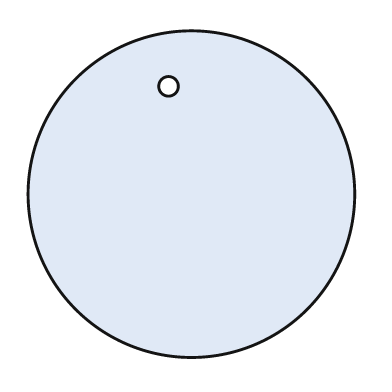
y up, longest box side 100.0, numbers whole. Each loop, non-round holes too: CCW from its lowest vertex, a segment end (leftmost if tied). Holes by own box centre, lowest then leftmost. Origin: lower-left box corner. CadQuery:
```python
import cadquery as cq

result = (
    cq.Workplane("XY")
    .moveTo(50.0, 50.0)
    .circle(50.0)
    .moveTo(43.0, 83.0)
    .circle(3.0)
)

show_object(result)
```